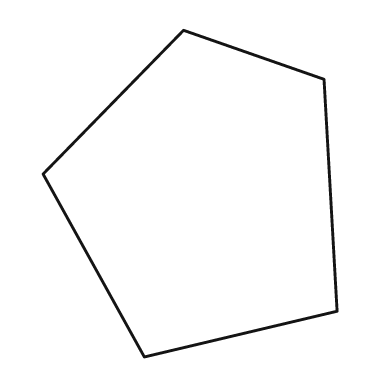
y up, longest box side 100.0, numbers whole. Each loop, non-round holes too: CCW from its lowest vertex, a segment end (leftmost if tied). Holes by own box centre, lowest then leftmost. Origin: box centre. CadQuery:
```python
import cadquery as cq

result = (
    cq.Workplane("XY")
    .moveTo(-14.0, -50.0)
    .lineTo(45.0, -36.0)
    .lineTo(41.0, 35.0)
    .lineTo(-2.0, 50.0)
    .lineTo(-45.0, 6.0)
    .close()
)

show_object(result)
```